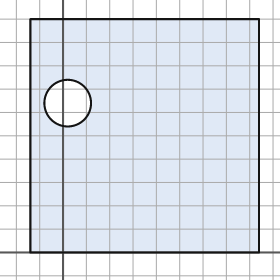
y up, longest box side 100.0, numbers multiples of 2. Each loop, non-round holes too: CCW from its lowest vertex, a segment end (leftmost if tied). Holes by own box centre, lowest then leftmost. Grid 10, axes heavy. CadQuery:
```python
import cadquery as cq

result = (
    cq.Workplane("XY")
    .moveTo(-14.0, 0.0)
    .lineTo(84.0, 0.0)
    .lineTo(84.0, 100.0)
    .lineTo(-14.0, 100.0)
    .close()
    .moveTo(2.0, 64.0)
    .circle(10.0)
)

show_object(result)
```